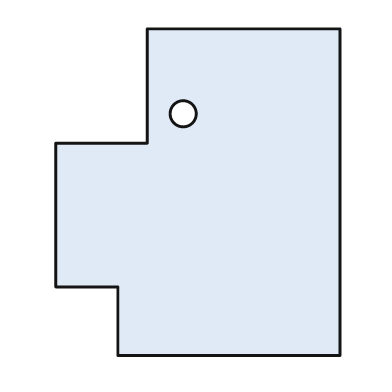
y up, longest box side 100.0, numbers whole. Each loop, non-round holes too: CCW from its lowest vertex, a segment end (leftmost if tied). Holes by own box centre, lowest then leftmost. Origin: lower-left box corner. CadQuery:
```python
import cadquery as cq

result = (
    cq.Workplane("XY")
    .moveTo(19.0, 0.0)
    .lineTo(87.0, 0.0)
    .lineTo(87.0, 100.0)
    .lineTo(28.0, 100.0)
    .lineTo(28.0, 65.0)
    .lineTo(0.0, 65.0)
    .lineTo(0.0, 21.0)
    .lineTo(19.0, 21.0)
    .close()
    .moveTo(39.0, 74.0)
    .circle(4.0)
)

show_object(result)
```